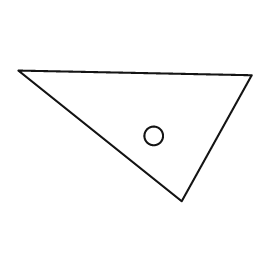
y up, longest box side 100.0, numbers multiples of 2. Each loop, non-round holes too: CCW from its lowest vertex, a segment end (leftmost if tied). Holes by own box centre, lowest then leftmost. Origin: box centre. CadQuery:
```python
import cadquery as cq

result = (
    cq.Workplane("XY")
    .moveTo(20.0, -28.0)
    .lineTo(50.0, 26.0)
    .lineTo(-50.0, 28.0)
    .close()
    .moveTo(8.0, 0.0)
    .circle(4.0)
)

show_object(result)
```